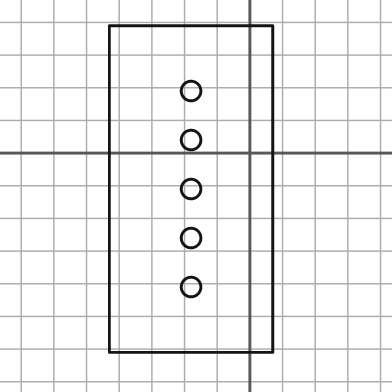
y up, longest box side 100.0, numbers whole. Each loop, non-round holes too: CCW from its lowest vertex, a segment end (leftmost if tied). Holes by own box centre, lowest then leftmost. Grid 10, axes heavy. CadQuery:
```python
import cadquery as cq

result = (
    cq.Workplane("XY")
    .moveTo(-43.0, -61.0)
    .lineTo(7.0, -61.0)
    .lineTo(7.0, 39.0)
    .lineTo(-43.0, 39.0)
    .close()
    .moveTo(-18.0, -41.0)
    .circle(3.0)
    .moveTo(-18.0, -26.0)
    .circle(3.0)
    .moveTo(-18.0, -11.0)
    .circle(3.0)
    .moveTo(-18.0, 4.0)
    .circle(3.0)
    .moveTo(-18.0, 19.0)
    .circle(3.0)
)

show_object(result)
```